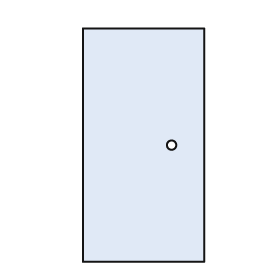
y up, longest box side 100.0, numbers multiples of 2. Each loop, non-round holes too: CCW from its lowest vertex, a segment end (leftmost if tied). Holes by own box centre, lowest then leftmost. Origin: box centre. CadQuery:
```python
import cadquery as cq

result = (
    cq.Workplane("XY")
    .moveTo(-26.0, -50.0)
    .lineTo(26.0, -50.0)
    .lineTo(26.0, 50.0)
    .lineTo(-26.0, 50.0)
    .close()
    .moveTo(12.0, 0.0)
    .circle(2.0)
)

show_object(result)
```